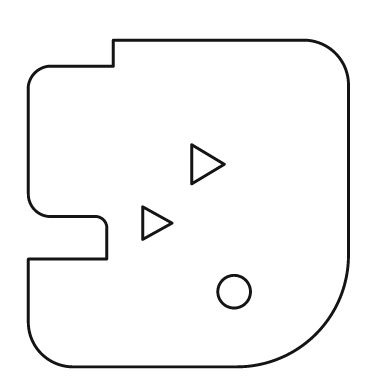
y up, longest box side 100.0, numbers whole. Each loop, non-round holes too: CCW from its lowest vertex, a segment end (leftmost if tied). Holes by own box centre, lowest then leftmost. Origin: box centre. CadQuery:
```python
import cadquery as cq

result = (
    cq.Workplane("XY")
    .moveTo(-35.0, -50.0)
    .lineTo(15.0, -50.0)
    .threePointArc((39.0, -40.0), (49.0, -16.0))
    .lineTo(49.0, 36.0)
    .threePointArc((45.0, 46.0), (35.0, 50.0))
    .lineTo(-23.0, 50.0)
    .lineTo(-23.0, 42.0)
    .lineTo(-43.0, 42.0)
    .threePointArc((-47.0, 40.0), (-49.0, 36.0))
    .lineTo(-49.0, 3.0)
    .threePointArc((-47.0, -2.0), (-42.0, -4.0))
    .lineTo(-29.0, -4.0)
    .threePointArc((-26.0, -5.0), (-25.0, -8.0))
    .lineTo(-25.0, -17.0)
    .lineTo(-49.0, -17.0)
    .lineTo(-49.0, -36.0)
    .threePointArc((-45.0, -46.0), (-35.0, -50.0))
    .close()
    .moveTo(14.0, -27.0)
    .circle(5.0)
    .moveTo(-14.0, -11.0)
    .lineTo(-5.0, -6.0)
    .lineTo(-14.0, -1.0)
    .close()
    .moveTo(1.0, 6.0)
    .lineTo(11.0, 12.0)
    .lineTo(1.0, 18.0)
    .close()
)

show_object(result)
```